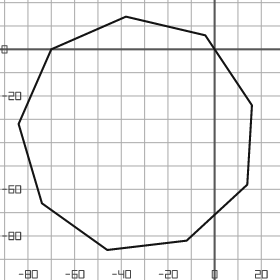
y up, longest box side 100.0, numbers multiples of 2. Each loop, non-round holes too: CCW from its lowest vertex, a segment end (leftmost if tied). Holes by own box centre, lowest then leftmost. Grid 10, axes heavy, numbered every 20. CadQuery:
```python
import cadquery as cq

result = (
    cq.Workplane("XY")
    .moveTo(-46.0, -86.0)
    .lineTo(-12.0, -82.0)
    .lineTo(14.0, -58.0)
    .lineTo(16.0, -24.0)
    .lineTo(-4.0, 6.0)
    .lineTo(-38.0, 14.0)
    .lineTo(-70.0, 0.0)
    .lineTo(-84.0, -32.0)
    .lineTo(-74.0, -66.0)
    .close()
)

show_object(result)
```